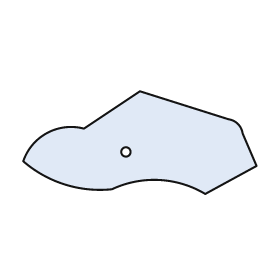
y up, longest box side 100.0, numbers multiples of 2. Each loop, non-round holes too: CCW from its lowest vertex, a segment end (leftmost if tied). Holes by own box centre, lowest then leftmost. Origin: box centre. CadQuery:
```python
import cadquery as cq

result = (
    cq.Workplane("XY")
    .moveTo(28.0, -22.0)
    .lineTo(50.0, -10.0)
    .lineTo(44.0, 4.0)
    .threePointArc((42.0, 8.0), (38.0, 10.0))
    .lineTo(0.0, 22.0)
    .lineTo(-24.0, 6.0)
    .threePointArc((-40.0, 4.0), (-50.0, -8.0))
    .threePointArc((-32.0, -18.0), (-12.0, -20.0))
    .threePointArc((8.0, -16.0), (28.0, -22.0))
    .close()
    .moveTo(-6.0, -4.0)
    .circle(2.0)
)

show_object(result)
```